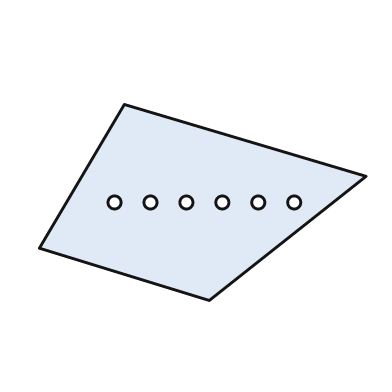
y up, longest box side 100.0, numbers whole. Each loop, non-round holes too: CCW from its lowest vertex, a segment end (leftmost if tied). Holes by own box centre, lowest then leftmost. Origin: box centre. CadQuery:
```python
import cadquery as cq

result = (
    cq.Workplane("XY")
    .moveTo(2.0, -30.0)
    .lineTo(50.0, 8.0)
    .lineTo(-24.0, 30.0)
    .lineTo(-50.0, -14.0)
    .close()
    .moveTo(-27.0, 0.0)
    .circle(2.0)
    .moveTo(-16.0, 0.0)
    .circle(2.0)
    .moveTo(-5.0, 0.0)
    .circle(2.0)
    .moveTo(6.0, 0.0)
    .circle(2.0)
    .moveTo(17.0, 0.0)
    .circle(2.0)
    .moveTo(28.0, 0.0)
    .circle(2.0)
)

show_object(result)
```